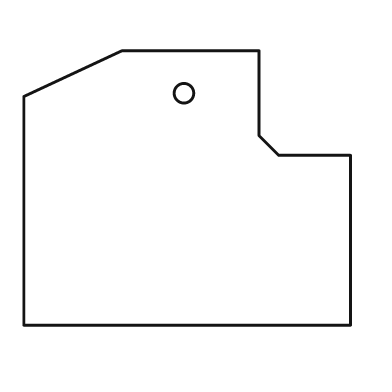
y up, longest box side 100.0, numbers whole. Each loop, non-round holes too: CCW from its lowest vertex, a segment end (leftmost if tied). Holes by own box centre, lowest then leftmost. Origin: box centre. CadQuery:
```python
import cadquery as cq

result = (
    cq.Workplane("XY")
    .moveTo(-50.0, -42.0)
    .lineTo(50.0, -42.0)
    .lineTo(50.0, 10.0)
    .lineTo(28.0, 10.0)
    .lineTo(22.0, 16.0)
    .lineTo(22.0, 42.0)
    .lineTo(-20.0, 42.0)
    .lineTo(-50.0, 28.0)
    .close()
    .moveTo(-1.0, 29.0)
    .circle(3.0)
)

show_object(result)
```